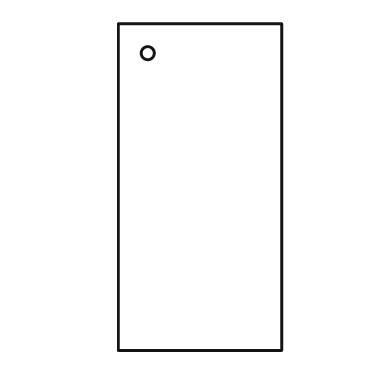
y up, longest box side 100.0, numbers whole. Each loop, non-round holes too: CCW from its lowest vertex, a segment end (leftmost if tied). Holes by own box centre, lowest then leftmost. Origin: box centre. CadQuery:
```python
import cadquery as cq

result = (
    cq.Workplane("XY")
    .moveTo(-25.0, -50.0)
    .lineTo(25.0, -50.0)
    .lineTo(25.0, 50.0)
    .lineTo(-25.0, 50.0)
    .close()
    .moveTo(-16.0, 41.0)
    .circle(2.0)
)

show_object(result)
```